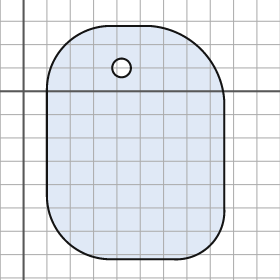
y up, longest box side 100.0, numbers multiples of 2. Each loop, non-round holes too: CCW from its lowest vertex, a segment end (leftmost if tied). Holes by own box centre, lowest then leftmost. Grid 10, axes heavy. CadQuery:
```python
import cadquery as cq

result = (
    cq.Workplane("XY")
    .moveTo(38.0, -72.0)
    .lineTo(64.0, -72.0)
    .threePointArc((80.0, -66.0), (86.0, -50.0))
    .lineTo(86.0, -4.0)
    .threePointArc((76.0, 18.0), (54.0, 28.0))
    .lineTo(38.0, 28.0)
    .threePointArc((18.0, 20.0), (10.0, 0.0))
    .lineTo(10.0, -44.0)
    .threePointArc((18.0, -64.0), (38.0, -72.0))
    .close()
    .moveTo(42.0, 10.0)
    .circle(4.0)
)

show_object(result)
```